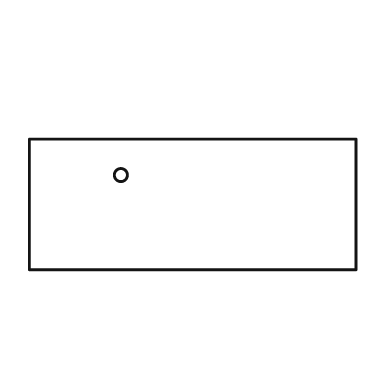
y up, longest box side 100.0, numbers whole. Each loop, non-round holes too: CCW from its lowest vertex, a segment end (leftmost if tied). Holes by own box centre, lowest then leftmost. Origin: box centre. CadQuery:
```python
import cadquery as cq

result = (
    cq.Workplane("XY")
    .moveTo(-50.0, -20.0)
    .lineTo(50.0, -20.0)
    .lineTo(50.0, 20.0)
    .lineTo(-50.0, 20.0)
    .close()
    .moveTo(-22.0, 9.0)
    .circle(2.0)
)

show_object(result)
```